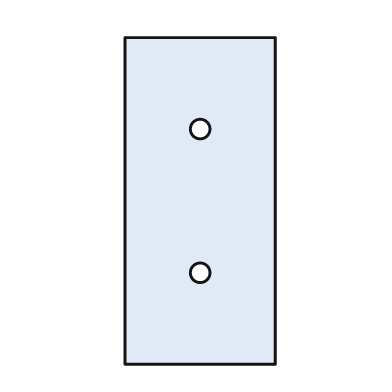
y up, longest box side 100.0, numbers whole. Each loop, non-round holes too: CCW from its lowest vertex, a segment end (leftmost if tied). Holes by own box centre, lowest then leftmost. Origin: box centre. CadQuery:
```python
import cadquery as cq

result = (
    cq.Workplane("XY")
    .moveTo(-23.0, -50.0)
    .lineTo(23.0, -50.0)
    .lineTo(23.0, 50.0)
    .lineTo(-23.0, 50.0)
    .close()
    .moveTo(0.0, -22.0)
    .circle(3.0)
    .moveTo(0.0, 22.0)
    .circle(3.0)
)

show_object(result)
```